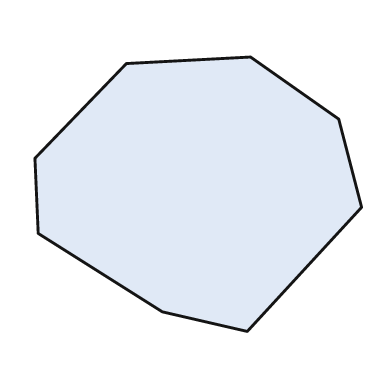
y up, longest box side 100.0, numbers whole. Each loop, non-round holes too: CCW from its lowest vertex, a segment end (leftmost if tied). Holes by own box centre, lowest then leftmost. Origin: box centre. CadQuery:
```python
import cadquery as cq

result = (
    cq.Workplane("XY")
    .moveTo(15.0, -42.0)
    .lineTo(50.0, -4.0)
    .lineTo(43.0, 23.0)
    .lineTo(16.0, 42.0)
    .lineTo(-22.0, 40.0)
    .lineTo(-50.0, 11.0)
    .lineTo(-49.0, -12.0)
    .lineTo(-11.0, -36.0)
    .close()
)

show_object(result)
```